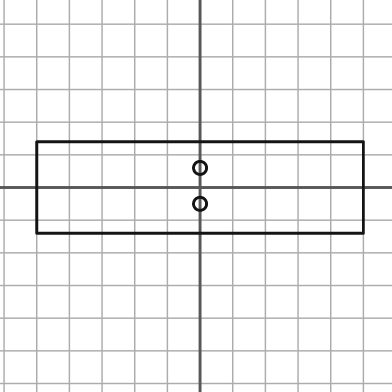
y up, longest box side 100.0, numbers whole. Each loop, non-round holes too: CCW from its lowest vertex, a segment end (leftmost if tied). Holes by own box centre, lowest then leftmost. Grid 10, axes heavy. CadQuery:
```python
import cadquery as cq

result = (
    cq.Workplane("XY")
    .moveTo(-50.0, -14.0)
    .lineTo(50.0, -14.0)
    .lineTo(50.0, 14.0)
    .lineTo(-50.0, 14.0)
    .close()
    .moveTo(0.0, -5.0)
    .circle(2.0)
    .moveTo(0.0, 6.0)
    .circle(2.0)
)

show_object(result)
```